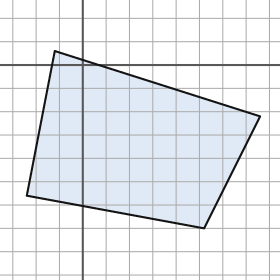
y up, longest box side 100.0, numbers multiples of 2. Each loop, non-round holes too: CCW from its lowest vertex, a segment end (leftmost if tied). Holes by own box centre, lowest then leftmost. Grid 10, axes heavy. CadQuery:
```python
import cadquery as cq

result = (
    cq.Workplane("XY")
    .moveTo(52.0, -70.0)
    .lineTo(76.0, -22.0)
    .lineTo(-12.0, 6.0)
    .lineTo(-24.0, -56.0)
    .close()
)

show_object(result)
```